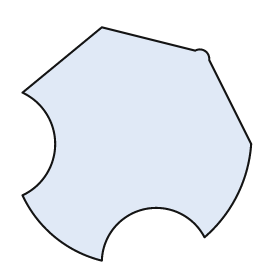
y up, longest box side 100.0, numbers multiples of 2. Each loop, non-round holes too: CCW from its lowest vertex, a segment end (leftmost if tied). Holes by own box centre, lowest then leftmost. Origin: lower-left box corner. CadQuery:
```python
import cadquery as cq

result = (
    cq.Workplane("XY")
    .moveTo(34.0, 0.0)
    .threePointArc((52.0, 22.0), (78.0, 10.0))
    .threePointArc((92.0, 28.0), (98.0, 50.0))
    .lineTo(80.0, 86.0)
    .threePointArc((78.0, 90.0), (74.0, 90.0))
    .lineTo(34.0, 100.0)
    .lineTo(0.0, 72.0)
    .threePointArc((14.0, 50.0), (0.0, 28.0))
    .threePointArc((14.0, 10.0), (34.0, 0.0))
    .close()
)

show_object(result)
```